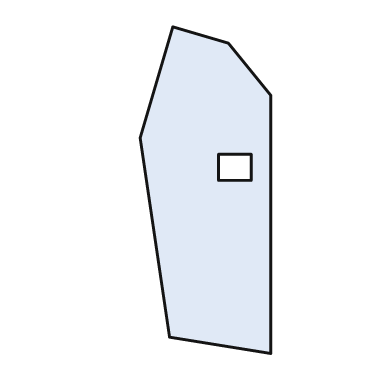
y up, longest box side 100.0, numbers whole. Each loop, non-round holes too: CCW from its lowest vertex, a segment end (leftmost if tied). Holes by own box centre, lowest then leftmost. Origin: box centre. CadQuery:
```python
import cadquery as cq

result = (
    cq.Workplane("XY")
    .moveTo(20.0, -50.0)
    .lineTo(20.0, 29.0)
    .lineTo(7.0, 45.0)
    .lineTo(-10.0, 50.0)
    .lineTo(-20.0, 16.0)
    .lineTo(-11.0, -45.0)
    .close()
    .moveTo(4.0, 3.0)
    .lineTo(14.0, 3.0)
    .lineTo(14.0, 11.0)
    .lineTo(4.0, 11.0)
    .close()
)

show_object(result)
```